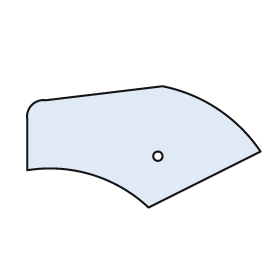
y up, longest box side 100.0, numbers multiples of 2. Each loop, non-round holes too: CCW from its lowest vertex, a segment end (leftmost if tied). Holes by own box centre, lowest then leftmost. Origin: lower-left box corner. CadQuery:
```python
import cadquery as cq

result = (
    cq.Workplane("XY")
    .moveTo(52.0, 0.0)
    .lineTo(100.0, 24.0)
    .threePointArc((82.0, 42.0), (58.0, 52.0))
    .lineTo(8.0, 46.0)
    .threePointArc((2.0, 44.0), (0.0, 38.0))
    .lineTo(0.0, 16.0)
    .threePointArc((28.0, 14.0), (52.0, 0.0))
    .close()
    .moveTo(56.0, 22.0)
    .circle(2.0)
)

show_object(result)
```